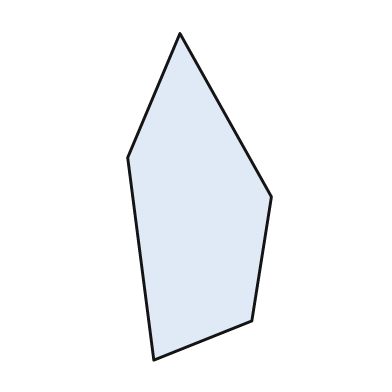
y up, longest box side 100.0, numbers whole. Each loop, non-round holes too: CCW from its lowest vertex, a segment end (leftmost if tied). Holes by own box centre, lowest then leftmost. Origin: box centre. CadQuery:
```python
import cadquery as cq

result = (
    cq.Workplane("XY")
    .moveTo(-14.0, -50.0)
    .lineTo(16.0, -38.0)
    .lineTo(22.0, 0.0)
    .lineTo(-6.0, 50.0)
    .lineTo(-22.0, 12.0)
    .close()
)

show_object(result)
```